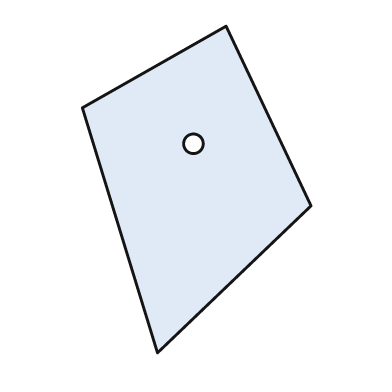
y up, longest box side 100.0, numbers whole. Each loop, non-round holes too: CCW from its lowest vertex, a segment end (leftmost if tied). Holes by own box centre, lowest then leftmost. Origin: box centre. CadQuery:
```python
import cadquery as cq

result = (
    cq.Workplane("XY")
    .moveTo(-12.0, -50.0)
    .lineTo(35.0, -5.0)
    .lineTo(9.0, 50.0)
    .lineTo(-35.0, 25.0)
    .close()
    .moveTo(-1.0, 14.0)
    .circle(3.0)
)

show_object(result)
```